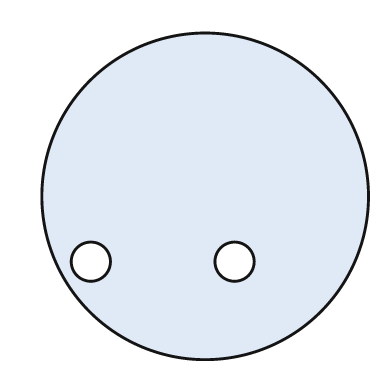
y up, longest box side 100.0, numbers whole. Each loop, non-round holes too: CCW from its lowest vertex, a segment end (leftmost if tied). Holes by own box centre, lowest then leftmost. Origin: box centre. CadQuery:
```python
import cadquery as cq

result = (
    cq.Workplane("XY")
    .moveTo(0.0, 0.0)
    .circle(50.0)
    .moveTo(-35.0, -20.0)
    .circle(6.0)
    .moveTo(9.0, -20.0)
    .circle(6.0)
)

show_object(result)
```